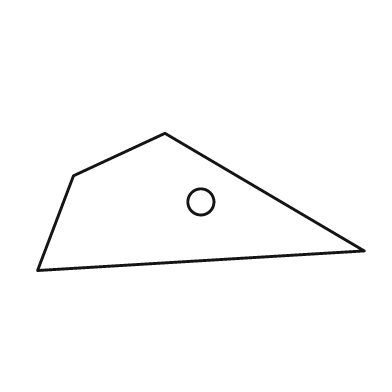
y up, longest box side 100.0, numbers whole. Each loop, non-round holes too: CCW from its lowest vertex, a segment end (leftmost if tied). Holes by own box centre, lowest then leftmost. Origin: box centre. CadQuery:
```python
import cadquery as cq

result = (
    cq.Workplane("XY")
    .moveTo(-50.0, -21.0)
    .lineTo(50.0, -15.0)
    .lineTo(-11.0, 21.0)
    .lineTo(-39.0, 8.0)
    .close()
    .moveTo(0.0, 0.0)
    .circle(4.0)
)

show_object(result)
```